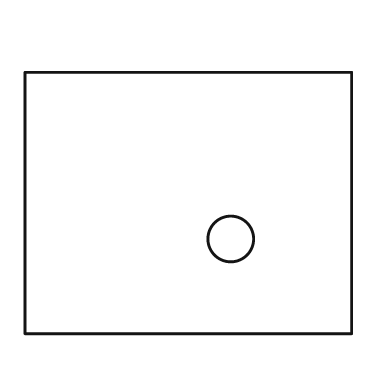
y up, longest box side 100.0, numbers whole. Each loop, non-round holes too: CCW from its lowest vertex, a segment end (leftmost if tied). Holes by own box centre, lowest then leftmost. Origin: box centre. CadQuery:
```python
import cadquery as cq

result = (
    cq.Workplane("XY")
    .moveTo(-50.0, -40.0)
    .lineTo(50.0, -40.0)
    .lineTo(50.0, 40.0)
    .lineTo(-50.0, 40.0)
    .close()
    .moveTo(13.0, -11.0)
    .circle(7.0)
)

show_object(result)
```